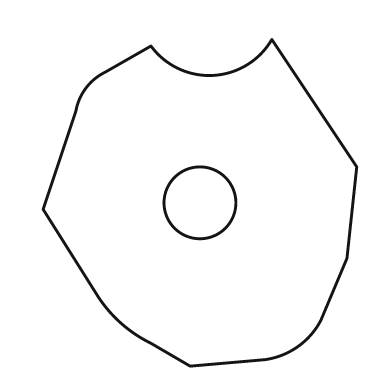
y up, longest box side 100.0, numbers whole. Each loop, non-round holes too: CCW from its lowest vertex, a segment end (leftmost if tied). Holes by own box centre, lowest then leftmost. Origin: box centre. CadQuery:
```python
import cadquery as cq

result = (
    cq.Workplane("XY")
    .moveTo(-3.0, -50.0)
    .lineTo(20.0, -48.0)
    .threePointArc((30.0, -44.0), (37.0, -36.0))
    .lineTo(45.0, -17.0)
    .lineTo(48.0, 11.0)
    .lineTo(22.0, 50.0)
    .threePointArc((4.0, 39.0), (-15.0, 48.0))
    .lineTo(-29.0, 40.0)
    .threePointArc((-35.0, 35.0), (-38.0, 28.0))
    .lineTo(-48.0, -2.0)
    .lineTo(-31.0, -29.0)
    .threePointArc((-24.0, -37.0), (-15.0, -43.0))
    .close()
    .moveTo(0.0, 0.0)
    .circle(11.0)
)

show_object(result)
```